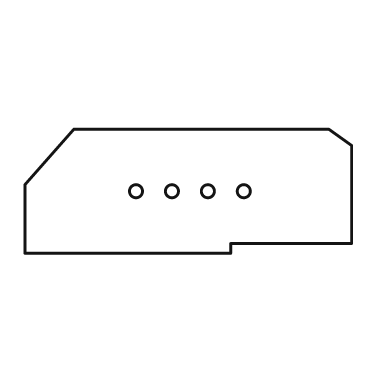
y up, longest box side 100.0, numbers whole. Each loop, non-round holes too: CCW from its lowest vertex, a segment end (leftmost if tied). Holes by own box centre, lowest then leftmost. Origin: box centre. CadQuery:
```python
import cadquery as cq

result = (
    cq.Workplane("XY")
    .moveTo(-50.0, -19.0)
    .lineTo(13.0, -19.0)
    .lineTo(13.0, -16.0)
    .lineTo(50.0, -16.0)
    .lineTo(50.0, 14.0)
    .lineTo(43.0, 19.0)
    .lineTo(-35.0, 19.0)
    .lineTo(-50.0, 2.0)
    .close()
    .moveTo(-16.0, 0.0)
    .circle(2.0)
    .moveTo(-5.0, 0.0)
    .circle(2.0)
    .moveTo(6.0, 0.0)
    .circle(2.0)
    .moveTo(17.0, 0.0)
    .circle(2.0)
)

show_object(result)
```